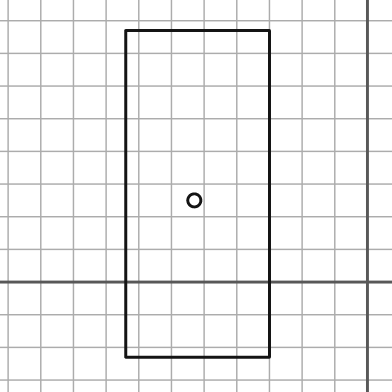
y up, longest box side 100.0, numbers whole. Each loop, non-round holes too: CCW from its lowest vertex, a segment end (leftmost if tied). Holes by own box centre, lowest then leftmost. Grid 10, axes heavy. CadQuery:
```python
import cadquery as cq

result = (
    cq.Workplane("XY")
    .moveTo(-74.0, -23.0)
    .lineTo(-30.0, -23.0)
    .lineTo(-30.0, 77.0)
    .lineTo(-74.0, 77.0)
    .close()
    .moveTo(-53.0, 25.0)
    .circle(2.0)
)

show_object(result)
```